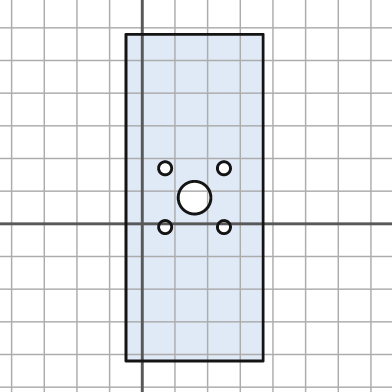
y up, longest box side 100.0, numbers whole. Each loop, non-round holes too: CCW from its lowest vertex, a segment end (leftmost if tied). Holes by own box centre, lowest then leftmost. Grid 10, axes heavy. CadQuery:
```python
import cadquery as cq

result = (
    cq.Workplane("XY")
    .moveTo(-5.0, -42.0)
    .lineTo(37.0, -42.0)
    .lineTo(37.0, 58.0)
    .lineTo(-5.0, 58.0)
    .close()
    .moveTo(7.0, -1.0)
    .circle(2.0)
    .moveTo(25.0, -1.0)
    .circle(2.0)
    .moveTo(16.0, 8.0)
    .circle(5.0)
    .moveTo(7.0, 17.0)
    .circle(2.0)
    .moveTo(25.0, 17.0)
    .circle(2.0)
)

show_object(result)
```